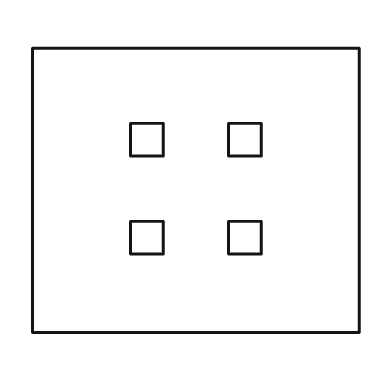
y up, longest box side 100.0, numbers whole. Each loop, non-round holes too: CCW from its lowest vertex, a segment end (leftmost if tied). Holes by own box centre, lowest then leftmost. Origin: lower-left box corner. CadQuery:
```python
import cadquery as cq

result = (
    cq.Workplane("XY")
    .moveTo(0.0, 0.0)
    .lineTo(100.0, 0.0)
    .lineTo(100.0, 87.0)
    .lineTo(0.0, 87.0)
    .close()
    .moveTo(30.0, 24.0)
    .lineTo(40.0, 24.0)
    .lineTo(40.0, 34.0)
    .lineTo(30.0, 34.0)
    .close()
    .moveTo(60.0, 24.0)
    .lineTo(70.0, 24.0)
    .lineTo(70.0, 34.0)
    .lineTo(60.0, 34.0)
    .close()
    .moveTo(30.0, 54.0)
    .lineTo(40.0, 54.0)
    .lineTo(40.0, 64.0)
    .lineTo(30.0, 64.0)
    .close()
    .moveTo(60.0, 54.0)
    .lineTo(70.0, 54.0)
    .lineTo(70.0, 64.0)
    .lineTo(60.0, 64.0)
    .close()
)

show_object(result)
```